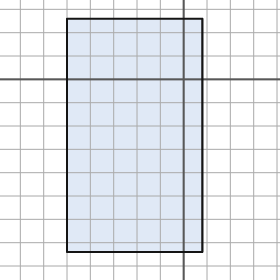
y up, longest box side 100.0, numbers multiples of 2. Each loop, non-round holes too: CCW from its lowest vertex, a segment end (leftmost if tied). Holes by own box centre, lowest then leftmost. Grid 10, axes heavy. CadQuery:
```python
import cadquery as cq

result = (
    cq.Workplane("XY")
    .moveTo(-50.0, -74.0)
    .lineTo(8.0, -74.0)
    .lineTo(8.0, 26.0)
    .lineTo(-50.0, 26.0)
    .close()
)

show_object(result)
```